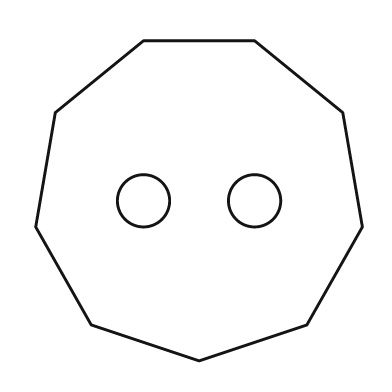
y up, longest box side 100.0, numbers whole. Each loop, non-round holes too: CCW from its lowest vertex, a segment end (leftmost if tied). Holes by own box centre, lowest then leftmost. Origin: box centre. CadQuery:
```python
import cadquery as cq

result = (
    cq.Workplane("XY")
    .moveTo(0.0, -49.0)
    .lineTo(33.0, -38.0)
    .lineTo(50.0, -8.0)
    .lineTo(44.0, 27.0)
    .lineTo(17.0, 49.0)
    .lineTo(-17.0, 49.0)
    .lineTo(-44.0, 27.0)
    .lineTo(-50.0, -8.0)
    .lineTo(-33.0, -38.0)
    .close()
    .moveTo(-17.0, 0.0)
    .circle(8.0)
    .moveTo(17.0, 0.0)
    .circle(8.0)
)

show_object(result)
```